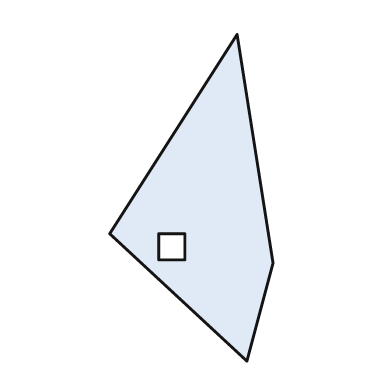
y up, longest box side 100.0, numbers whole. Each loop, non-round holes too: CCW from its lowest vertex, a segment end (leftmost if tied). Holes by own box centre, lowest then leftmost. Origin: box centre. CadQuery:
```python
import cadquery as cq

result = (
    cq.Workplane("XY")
    .moveTo(17.0, -50.0)
    .lineTo(25.0, -20.0)
    .lineTo(14.0, 50.0)
    .lineTo(-25.0, -11.0)
    .close()
    .moveTo(-10.0, -19.0)
    .lineTo(-2.0, -19.0)
    .lineTo(-2.0, -11.0)
    .lineTo(-10.0, -11.0)
    .close()
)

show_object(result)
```